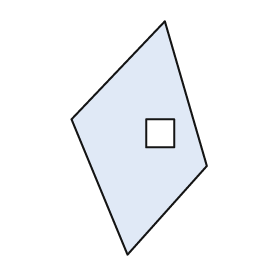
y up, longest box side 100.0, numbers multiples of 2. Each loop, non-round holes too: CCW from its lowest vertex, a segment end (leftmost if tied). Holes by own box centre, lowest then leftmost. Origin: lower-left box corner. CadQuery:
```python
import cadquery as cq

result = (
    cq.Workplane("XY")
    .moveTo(24.0, 0.0)
    .lineTo(58.0, 38.0)
    .lineTo(40.0, 100.0)
    .lineTo(0.0, 58.0)
    .close()
    .moveTo(32.0, 46.0)
    .lineTo(44.0, 46.0)
    .lineTo(44.0, 58.0)
    .lineTo(32.0, 58.0)
    .close()
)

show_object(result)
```